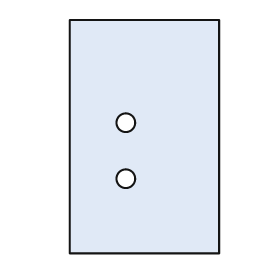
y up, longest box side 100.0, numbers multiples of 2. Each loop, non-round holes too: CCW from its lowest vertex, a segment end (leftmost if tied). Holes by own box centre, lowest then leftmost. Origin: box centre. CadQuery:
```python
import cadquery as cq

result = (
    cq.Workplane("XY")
    .moveTo(-32.0, -50.0)
    .lineTo(32.0, -50.0)
    .lineTo(32.0, 50.0)
    .lineTo(-32.0, 50.0)
    .close()
    .moveTo(-8.0, -18.0)
    .circle(4.0)
    .moveTo(-8.0, 6.0)
    .circle(4.0)
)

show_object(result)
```